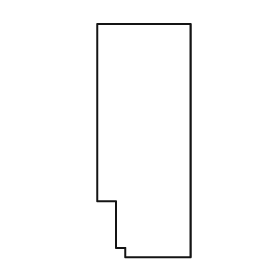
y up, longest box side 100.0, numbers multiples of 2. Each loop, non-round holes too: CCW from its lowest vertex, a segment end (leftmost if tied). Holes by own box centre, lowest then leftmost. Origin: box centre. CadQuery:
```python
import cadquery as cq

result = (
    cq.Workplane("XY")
    .moveTo(-8.0, -50.0)
    .lineTo(20.0, -50.0)
    .lineTo(20.0, 50.0)
    .lineTo(-20.0, 50.0)
    .lineTo(-20.0, -26.0)
    .lineTo(-12.0, -26.0)
    .lineTo(-12.0, -46.0)
    .lineTo(-8.0, -46.0)
    .close()
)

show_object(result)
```